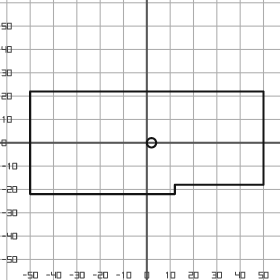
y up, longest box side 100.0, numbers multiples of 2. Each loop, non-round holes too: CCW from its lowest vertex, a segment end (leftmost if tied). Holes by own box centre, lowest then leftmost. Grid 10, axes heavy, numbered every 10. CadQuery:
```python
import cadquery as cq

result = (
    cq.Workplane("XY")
    .moveTo(-50.0, -22.0)
    .lineTo(12.0, -22.0)
    .lineTo(12.0, -18.0)
    .lineTo(50.0, -18.0)
    .lineTo(50.0, 22.0)
    .lineTo(-50.0, 22.0)
    .close()
    .moveTo(2.0, 0.0)
    .circle(2.0)
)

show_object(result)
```